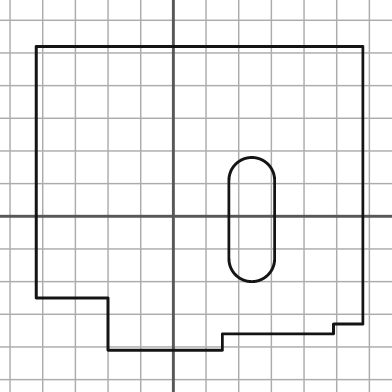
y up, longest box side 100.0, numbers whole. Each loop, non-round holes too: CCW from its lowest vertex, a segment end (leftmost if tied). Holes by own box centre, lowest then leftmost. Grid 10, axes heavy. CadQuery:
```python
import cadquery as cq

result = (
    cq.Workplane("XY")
    .moveTo(-20.0, -41.0)
    .lineTo(15.0, -41.0)
    .lineTo(15.0, -36.0)
    .lineTo(49.0, -36.0)
    .lineTo(49.0, -33.0)
    .lineTo(58.0, -33.0)
    .lineTo(58.0, 52.0)
    .lineTo(-42.0, 52.0)
    .lineTo(-42.0, -25.0)
    .lineTo(-20.0, -25.0)
    .close()
    .moveTo(17.0, -13.0)
    .threePointArc((24.0, -20.0), (31.0, -13.0))
    .lineTo(31.0, 11.0)
    .threePointArc((24.0, 18.0), (17.0, 11.0))
    .close()
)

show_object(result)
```